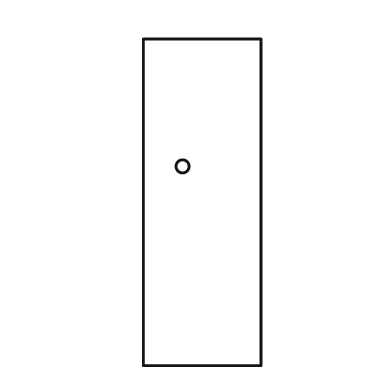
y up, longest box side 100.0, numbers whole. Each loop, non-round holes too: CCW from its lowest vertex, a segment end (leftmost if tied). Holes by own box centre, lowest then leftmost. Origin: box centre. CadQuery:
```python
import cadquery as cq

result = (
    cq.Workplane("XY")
    .moveTo(-18.0, -50.0)
    .lineTo(18.0, -50.0)
    .lineTo(18.0, 50.0)
    .lineTo(-18.0, 50.0)
    .close()
    .moveTo(-6.0, 11.0)
    .circle(2.0)
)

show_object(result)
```